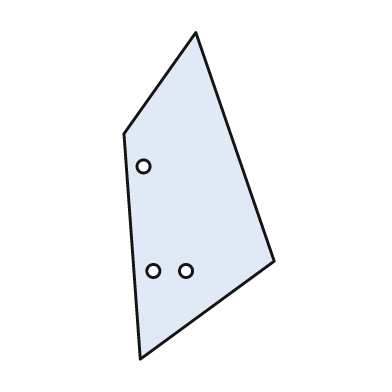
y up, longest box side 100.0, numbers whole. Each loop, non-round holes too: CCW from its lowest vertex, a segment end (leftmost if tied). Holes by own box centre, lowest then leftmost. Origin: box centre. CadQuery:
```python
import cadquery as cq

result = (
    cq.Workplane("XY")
    .moveTo(-18.0, -50.0)
    .lineTo(23.0, -20.0)
    .lineTo(-1.0, 50.0)
    .lineTo(-23.0, 19.0)
    .close()
    .moveTo(-14.0, -23.0)
    .circle(2.0)
    .moveTo(-4.0, -23.0)
    .circle(2.0)
    .moveTo(-17.0, 9.0)
    .circle(2.0)
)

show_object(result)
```